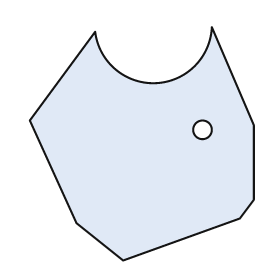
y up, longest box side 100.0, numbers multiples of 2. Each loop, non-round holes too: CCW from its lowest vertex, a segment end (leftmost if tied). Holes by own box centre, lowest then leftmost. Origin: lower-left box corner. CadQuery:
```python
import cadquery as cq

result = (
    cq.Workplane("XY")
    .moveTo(40.0, 0.0)
    .lineTo(90.0, 18.0)
    .lineTo(96.0, 26.0)
    .lineTo(96.0, 58.0)
    .lineTo(78.0, 100.0)
    .threePointArc((54.0, 76.0), (28.0, 98.0))
    .lineTo(0.0, 60.0)
    .lineTo(20.0, 16.0)
    .close()
    .moveTo(74.0, 56.0)
    .circle(4.0)
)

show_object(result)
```